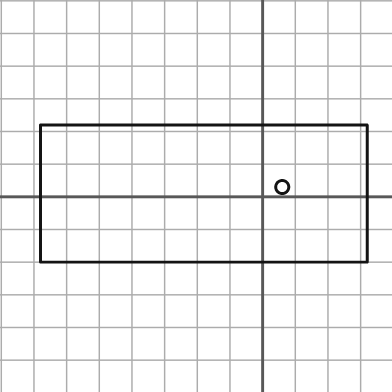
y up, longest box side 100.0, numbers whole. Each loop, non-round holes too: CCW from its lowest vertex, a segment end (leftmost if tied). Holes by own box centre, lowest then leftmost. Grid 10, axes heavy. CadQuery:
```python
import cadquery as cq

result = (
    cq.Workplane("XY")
    .moveTo(-68.0, -20.0)
    .lineTo(32.0, -20.0)
    .lineTo(32.0, 22.0)
    .lineTo(-68.0, 22.0)
    .close()
    .moveTo(6.0, 3.0)
    .circle(2.0)
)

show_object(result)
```